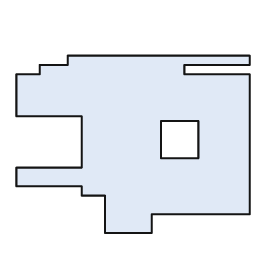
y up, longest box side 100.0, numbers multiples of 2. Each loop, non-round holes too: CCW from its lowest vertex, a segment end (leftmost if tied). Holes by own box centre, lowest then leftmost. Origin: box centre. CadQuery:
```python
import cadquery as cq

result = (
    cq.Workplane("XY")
    .moveTo(-12.0, -38.0)
    .lineTo(8.0, -38.0)
    .lineTo(8.0, -30.0)
    .lineTo(50.0, -30.0)
    .lineTo(50.0, 30.0)
    .lineTo(22.0, 30.0)
    .lineTo(22.0, 34.0)
    .lineTo(50.0, 34.0)
    .lineTo(50.0, 38.0)
    .lineTo(-28.0, 38.0)
    .lineTo(-28.0, 34.0)
    .lineTo(-40.0, 34.0)
    .lineTo(-40.0, 30.0)
    .lineTo(-50.0, 30.0)
    .lineTo(-50.0, 12.0)
    .lineTo(-22.0, 12.0)
    .lineTo(-22.0, -10.0)
    .lineTo(-50.0, -10.0)
    .lineTo(-50.0, -18.0)
    .lineTo(-22.0, -18.0)
    .lineTo(-22.0, -22.0)
    .lineTo(-12.0, -22.0)
    .close()
    .moveTo(12.0, -6.0)
    .lineTo(28.0, -6.0)
    .lineTo(28.0, 10.0)
    .lineTo(12.0, 10.0)
    .close()
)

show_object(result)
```